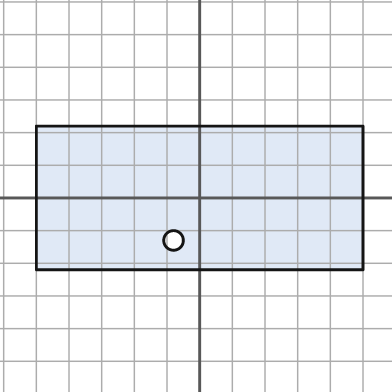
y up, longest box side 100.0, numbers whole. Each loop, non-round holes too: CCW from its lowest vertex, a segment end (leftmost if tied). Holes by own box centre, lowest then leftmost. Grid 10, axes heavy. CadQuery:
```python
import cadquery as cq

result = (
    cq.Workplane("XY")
    .moveTo(-50.0, -22.0)
    .lineTo(50.0, -22.0)
    .lineTo(50.0, 22.0)
    .lineTo(-50.0, 22.0)
    .close()
    .moveTo(-8.0, -13.0)
    .circle(3.0)
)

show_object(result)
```